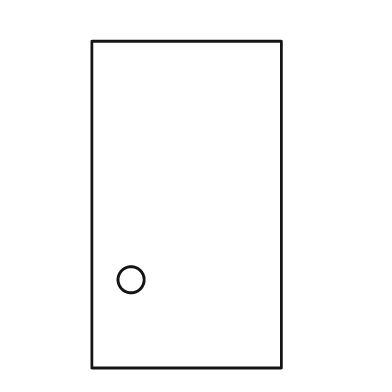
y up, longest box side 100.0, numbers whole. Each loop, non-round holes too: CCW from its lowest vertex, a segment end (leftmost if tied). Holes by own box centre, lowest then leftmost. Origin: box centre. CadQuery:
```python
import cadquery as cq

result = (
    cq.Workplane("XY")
    .moveTo(-29.0, -50.0)
    .lineTo(29.0, -50.0)
    .lineTo(29.0, 50.0)
    .lineTo(-29.0, 50.0)
    .close()
    .moveTo(-17.0, -23.0)
    .circle(4.0)
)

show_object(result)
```